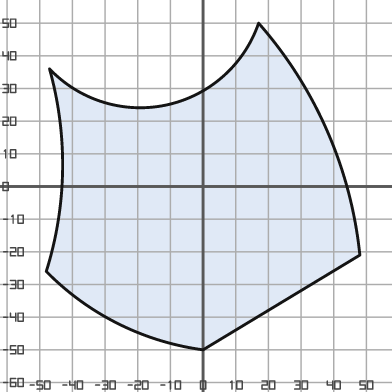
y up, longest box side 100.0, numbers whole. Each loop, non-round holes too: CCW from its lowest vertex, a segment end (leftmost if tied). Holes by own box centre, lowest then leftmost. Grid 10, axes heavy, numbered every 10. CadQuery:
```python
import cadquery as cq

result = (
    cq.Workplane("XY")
    .moveTo(0.0, -50.0)
    .lineTo(48.0, -21.0)
    .threePointArc((38.0, 17.0), (17.0, 50.0))
    .threePointArc((-11.0, 25.0), (-47.0, 36.0))
    .threePointArc((-43.0, 5.0), (-48.0, -26.0))
    .threePointArc((-26.0, -42.0), (0.0, -50.0))
    .close()
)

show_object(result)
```